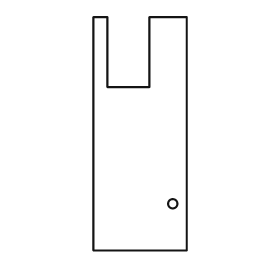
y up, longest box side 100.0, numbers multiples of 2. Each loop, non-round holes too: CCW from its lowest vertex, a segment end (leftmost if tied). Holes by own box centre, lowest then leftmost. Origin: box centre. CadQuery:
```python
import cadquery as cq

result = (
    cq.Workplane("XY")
    .moveTo(-20.0, -50.0)
    .lineTo(20.0, -50.0)
    .lineTo(20.0, 50.0)
    .lineTo(4.0, 50.0)
    .lineTo(4.0, 20.0)
    .lineTo(-14.0, 20.0)
    .lineTo(-14.0, 50.0)
    .lineTo(-20.0, 50.0)
    .close()
    .moveTo(14.0, -30.0)
    .circle(2.0)
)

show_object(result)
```